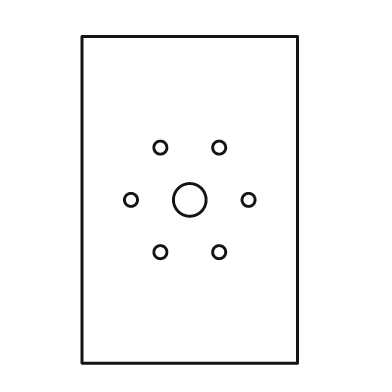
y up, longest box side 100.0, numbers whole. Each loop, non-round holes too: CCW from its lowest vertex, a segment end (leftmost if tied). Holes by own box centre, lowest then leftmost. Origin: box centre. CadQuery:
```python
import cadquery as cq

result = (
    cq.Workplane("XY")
    .moveTo(-33.0, -50.0)
    .lineTo(33.0, -50.0)
    .lineTo(33.0, 50.0)
    .lineTo(-33.0, 50.0)
    .close()
    .moveTo(-9.0, -16.0)
    .circle(2.0)
    .moveTo(9.0, -16.0)
    .circle(2.0)
    .moveTo(-18.0, 0.0)
    .circle(2.0)
    .moveTo(0.0, 0.0)
    .circle(5.0)
    .moveTo(18.0, 0.0)
    .circle(2.0)
    .moveTo(-9.0, 16.0)
    .circle(2.0)
    .moveTo(9.0, 16.0)
    .circle(2.0)
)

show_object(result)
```